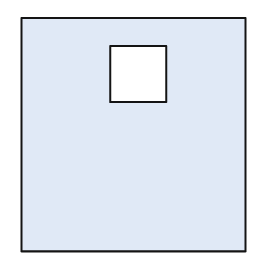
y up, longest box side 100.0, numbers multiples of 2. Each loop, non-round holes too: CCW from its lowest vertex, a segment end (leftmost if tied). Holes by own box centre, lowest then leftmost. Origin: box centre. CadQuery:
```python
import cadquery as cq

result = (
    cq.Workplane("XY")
    .moveTo(-48.0, -50.0)
    .lineTo(48.0, -50.0)
    .lineTo(48.0, 50.0)
    .lineTo(-48.0, 50.0)
    .close()
    .moveTo(-10.0, 14.0)
    .lineTo(14.0, 14.0)
    .lineTo(14.0, 38.0)
    .lineTo(-10.0, 38.0)
    .close()
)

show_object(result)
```